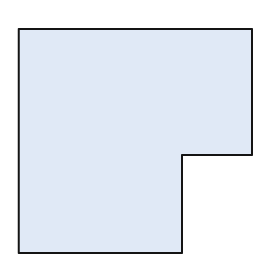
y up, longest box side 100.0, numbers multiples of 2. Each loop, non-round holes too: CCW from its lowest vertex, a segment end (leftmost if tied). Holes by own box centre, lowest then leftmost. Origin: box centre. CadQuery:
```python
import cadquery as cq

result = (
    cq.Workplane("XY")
    .moveTo(-50.0, -48.0)
    .lineTo(20.0, -48.0)
    .lineTo(20.0, -6.0)
    .lineTo(50.0, -6.0)
    .lineTo(50.0, 48.0)
    .lineTo(-50.0, 48.0)
    .close()
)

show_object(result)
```